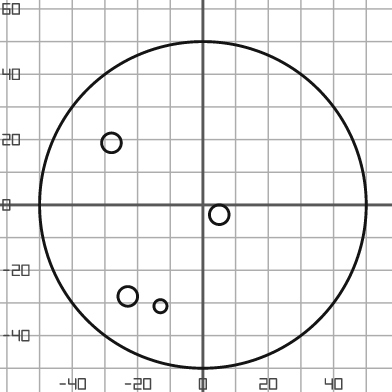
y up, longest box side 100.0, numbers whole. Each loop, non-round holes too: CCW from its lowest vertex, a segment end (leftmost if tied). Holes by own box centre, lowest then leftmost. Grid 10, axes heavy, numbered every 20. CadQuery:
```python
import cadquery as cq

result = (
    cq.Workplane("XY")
    .moveTo(0.0, 0.0)
    .circle(50.0)
    .moveTo(-13.0, -31.0)
    .circle(2.0)
    .moveTo(-23.0, -28.0)
    .circle(3.0)
    .moveTo(5.0, -3.0)
    .circle(3.0)
    .moveTo(-28.0, 19.0)
    .circle(3.0)
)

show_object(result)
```